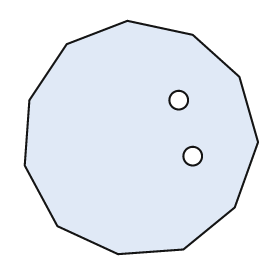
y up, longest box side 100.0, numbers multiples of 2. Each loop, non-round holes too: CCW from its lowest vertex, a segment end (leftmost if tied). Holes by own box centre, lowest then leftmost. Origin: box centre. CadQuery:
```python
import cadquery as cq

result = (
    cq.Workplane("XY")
    .moveTo(-10.0, -50.0)
    .lineTo(18.0, -48.0)
    .lineTo(40.0, -30.0)
    .lineTo(50.0, -2.0)
    .lineTo(42.0, 26.0)
    .lineTo(22.0, 44.0)
    .lineTo(-6.0, 50.0)
    .lineTo(-32.0, 40.0)
    .lineTo(-48.0, 16.0)
    .lineTo(-50.0, -12.0)
    .lineTo(-36.0, -38.0)
    .close()
    .moveTo(22.0, -8.0)
    .circle(4.0)
    .moveTo(16.0, 16.0)
    .circle(4.0)
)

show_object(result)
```